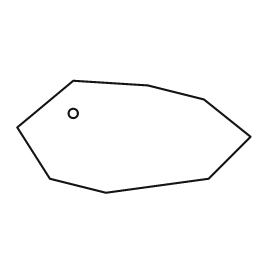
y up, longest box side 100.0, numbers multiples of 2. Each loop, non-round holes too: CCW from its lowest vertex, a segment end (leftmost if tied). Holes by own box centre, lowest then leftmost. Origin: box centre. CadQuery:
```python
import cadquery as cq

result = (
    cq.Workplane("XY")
    .moveTo(-12.0, -24.0)
    .lineTo(32.0, -18.0)
    .lineTo(50.0, 0.0)
    .lineTo(30.0, 16.0)
    .lineTo(6.0, 22.0)
    .lineTo(-26.0, 24.0)
    .lineTo(-50.0, 4.0)
    .lineTo(-36.0, -18.0)
    .close()
    .moveTo(-26.0, 10.0)
    .circle(2.0)
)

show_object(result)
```